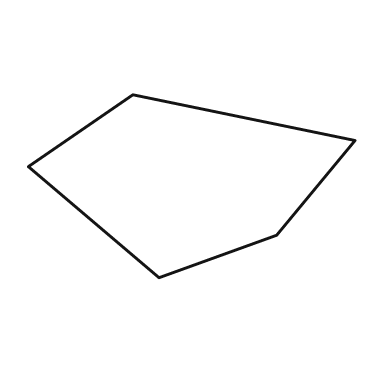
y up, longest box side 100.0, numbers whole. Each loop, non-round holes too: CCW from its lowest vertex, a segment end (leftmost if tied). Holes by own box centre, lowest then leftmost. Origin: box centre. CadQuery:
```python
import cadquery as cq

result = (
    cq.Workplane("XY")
    .moveTo(-10.0, -28.0)
    .lineTo(26.0, -15.0)
    .lineTo(50.0, 14.0)
    .lineTo(-18.0, 28.0)
    .lineTo(-50.0, 6.0)
    .close()
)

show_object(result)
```